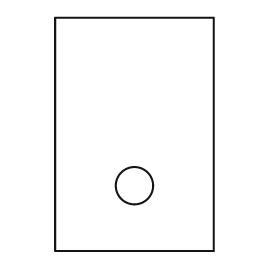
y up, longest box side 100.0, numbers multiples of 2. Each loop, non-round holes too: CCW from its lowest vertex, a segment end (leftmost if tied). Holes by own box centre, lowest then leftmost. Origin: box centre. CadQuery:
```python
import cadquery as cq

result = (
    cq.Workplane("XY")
    .moveTo(-34.0, -50.0)
    .lineTo(34.0, -50.0)
    .lineTo(34.0, 50.0)
    .lineTo(-34.0, 50.0)
    .close()
    .moveTo(0.0, -22.0)
    .circle(8.0)
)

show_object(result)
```